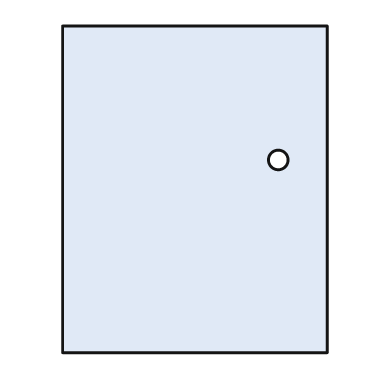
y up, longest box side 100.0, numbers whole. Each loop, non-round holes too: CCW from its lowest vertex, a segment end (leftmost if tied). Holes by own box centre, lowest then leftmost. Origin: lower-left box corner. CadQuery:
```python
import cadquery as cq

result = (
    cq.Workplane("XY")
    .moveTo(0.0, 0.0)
    .lineTo(81.0, 0.0)
    .lineTo(81.0, 100.0)
    .lineTo(0.0, 100.0)
    .close()
    .moveTo(66.0, 59.0)
    .circle(3.0)
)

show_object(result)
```